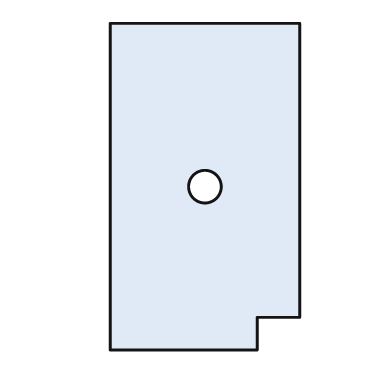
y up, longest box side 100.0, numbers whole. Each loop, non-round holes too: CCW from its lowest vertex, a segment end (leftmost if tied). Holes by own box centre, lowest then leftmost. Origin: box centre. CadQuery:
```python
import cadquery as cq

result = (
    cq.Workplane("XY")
    .moveTo(-29.0, -50.0)
    .lineTo(16.0, -50.0)
    .lineTo(16.0, -40.0)
    .lineTo(29.0, -40.0)
    .lineTo(29.0, 50.0)
    .lineTo(-29.0, 50.0)
    .close()
    .moveTo(0.0, 0.0)
    .circle(5.0)
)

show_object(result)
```